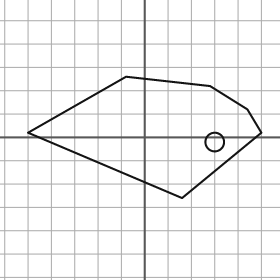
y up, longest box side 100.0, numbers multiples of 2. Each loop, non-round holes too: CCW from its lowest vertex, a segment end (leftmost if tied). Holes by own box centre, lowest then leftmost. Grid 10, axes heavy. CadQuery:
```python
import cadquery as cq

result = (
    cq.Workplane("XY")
    .moveTo(16.0, -26.0)
    .lineTo(50.0, 2.0)
    .lineTo(44.0, 12.0)
    .lineTo(28.0, 22.0)
    .lineTo(-8.0, 26.0)
    .lineTo(-50.0, 2.0)
    .close()
    .moveTo(30.0, -2.0)
    .circle(4.0)
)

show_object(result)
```